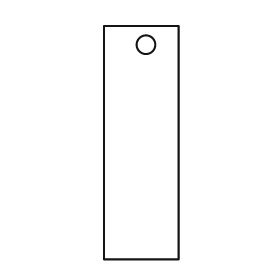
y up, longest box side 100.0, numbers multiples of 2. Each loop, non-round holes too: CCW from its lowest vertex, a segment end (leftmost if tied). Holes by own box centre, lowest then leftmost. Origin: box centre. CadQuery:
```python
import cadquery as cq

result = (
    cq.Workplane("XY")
    .moveTo(-16.0, -50.0)
    .lineTo(16.0, -50.0)
    .lineTo(16.0, 50.0)
    .lineTo(-16.0, 50.0)
    .close()
    .moveTo(2.0, 42.0)
    .circle(4.0)
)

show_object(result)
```